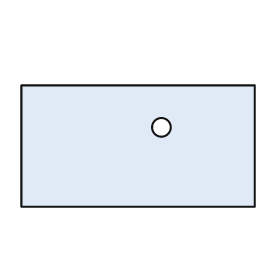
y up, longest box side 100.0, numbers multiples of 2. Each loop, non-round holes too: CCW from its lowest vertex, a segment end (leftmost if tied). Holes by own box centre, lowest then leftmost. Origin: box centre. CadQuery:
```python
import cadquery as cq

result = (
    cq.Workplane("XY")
    .moveTo(-50.0, -26.0)
    .lineTo(50.0, -26.0)
    .lineTo(50.0, 26.0)
    .lineTo(-50.0, 26.0)
    .close()
    .moveTo(10.0, 8.0)
    .circle(4.0)
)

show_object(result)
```